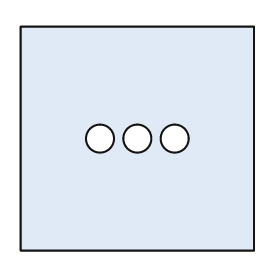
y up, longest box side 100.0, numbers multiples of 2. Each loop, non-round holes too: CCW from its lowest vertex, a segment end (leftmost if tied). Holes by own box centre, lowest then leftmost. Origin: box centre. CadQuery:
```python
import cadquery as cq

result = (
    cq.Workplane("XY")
    .moveTo(-50.0, -48.0)
    .lineTo(50.0, -48.0)
    .lineTo(50.0, 48.0)
    .lineTo(-50.0, 48.0)
    .close()
    .moveTo(-16.0, 0.0)
    .circle(6.0)
    .moveTo(0.0, 0.0)
    .circle(6.0)
    .moveTo(16.0, 0.0)
    .circle(6.0)
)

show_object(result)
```